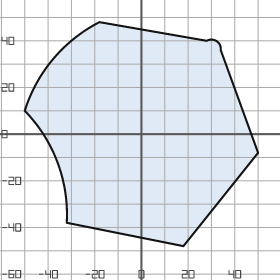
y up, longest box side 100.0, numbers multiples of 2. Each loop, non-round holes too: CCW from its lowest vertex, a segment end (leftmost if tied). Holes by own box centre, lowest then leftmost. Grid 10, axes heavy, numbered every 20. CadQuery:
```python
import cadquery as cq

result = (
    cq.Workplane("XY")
    .moveTo(18.0, -48.0)
    .lineTo(50.0, -8.0)
    .lineTo(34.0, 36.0)
    .threePointArc((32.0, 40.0), (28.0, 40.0))
    .lineTo(-18.0, 48.0)
    .threePointArc((-38.0, 32.0), (-50.0, 10.0))
    .threePointArc((-36.0, -12.0), (-32.0, -38.0))
    .close()
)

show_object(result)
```